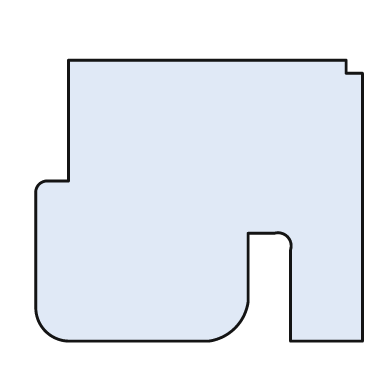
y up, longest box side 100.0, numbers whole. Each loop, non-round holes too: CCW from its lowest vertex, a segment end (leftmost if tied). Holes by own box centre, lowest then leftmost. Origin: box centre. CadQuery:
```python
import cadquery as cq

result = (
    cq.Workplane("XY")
    .moveTo(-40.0, -43.0)
    .lineTo(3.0, -43.0)
    .threePointArc((11.0, -39.0), (15.0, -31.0))
    .lineTo(15.0, -10.0)
    .lineTo(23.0, -10.0)
    .threePointArc((27.0, -11.0), (28.0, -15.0))
    .lineTo(28.0, -43.0)
    .lineTo(50.0, -43.0)
    .lineTo(50.0, 39.0)
    .lineTo(45.0, 39.0)
    .lineTo(45.0, 43.0)
    .lineTo(-40.0, 43.0)
    .lineTo(-40.0, 6.0)
    .lineTo(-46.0, 6.0)
    .threePointArc((-49.0, 5.0), (-50.0, 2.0))
    .lineTo(-50.0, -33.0)
    .threePointArc((-47.0, -40.0), (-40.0, -43.0))
    .close()
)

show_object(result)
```